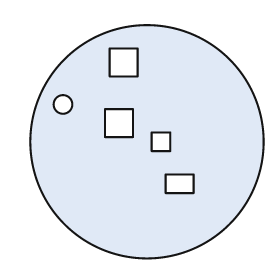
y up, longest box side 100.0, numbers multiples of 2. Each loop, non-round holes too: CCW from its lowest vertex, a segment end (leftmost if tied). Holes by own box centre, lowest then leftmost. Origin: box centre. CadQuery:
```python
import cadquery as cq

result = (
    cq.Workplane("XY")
    .moveTo(0.0, 0.0)
    .circle(50.0)
    .moveTo(8.0, -22.0)
    .lineTo(20.0, -22.0)
    .lineTo(20.0, -14.0)
    .lineTo(8.0, -14.0)
    .close()
    .moveTo(2.0, -4.0)
    .lineTo(10.0, -4.0)
    .lineTo(10.0, 4.0)
    .lineTo(2.0, 4.0)
    .close()
    .moveTo(-18.0, 2.0)
    .lineTo(-6.0, 2.0)
    .lineTo(-6.0, 14.0)
    .lineTo(-18.0, 14.0)
    .close()
    .moveTo(-36.0, 16.0)
    .circle(4.0)
    .moveTo(-16.0, 28.0)
    .lineTo(-4.0, 28.0)
    .lineTo(-4.0, 40.0)
    .lineTo(-16.0, 40.0)
    .close()
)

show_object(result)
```